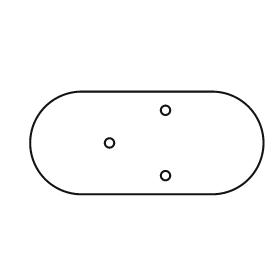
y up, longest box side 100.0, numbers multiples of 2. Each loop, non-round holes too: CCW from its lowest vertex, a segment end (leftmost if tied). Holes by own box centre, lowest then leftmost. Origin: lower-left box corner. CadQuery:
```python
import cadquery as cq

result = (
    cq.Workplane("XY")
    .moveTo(22.0, 0.0)
    .lineTo(78.0, 0.0)
    .threePointArc((100.0, 22.0), (78.0, 44.0))
    .lineTo(22.0, 44.0)
    .threePointArc((0.0, 22.0), (22.0, 0.0))
    .close()
    .moveTo(58.0, 8.0)
    .circle(2.0)
    .moveTo(34.0, 22.0)
    .circle(2.0)
    .moveTo(58.0, 36.0)
    .circle(2.0)
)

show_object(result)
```